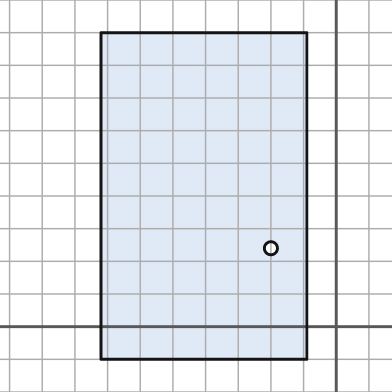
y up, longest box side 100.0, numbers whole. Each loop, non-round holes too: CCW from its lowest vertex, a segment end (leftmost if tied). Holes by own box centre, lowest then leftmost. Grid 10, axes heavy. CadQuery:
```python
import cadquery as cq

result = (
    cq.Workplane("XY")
    .moveTo(-72.0, -10.0)
    .lineTo(-9.0, -10.0)
    .lineTo(-9.0, 90.0)
    .lineTo(-72.0, 90.0)
    .close()
    .moveTo(-20.0, 24.0)
    .circle(2.0)
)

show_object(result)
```